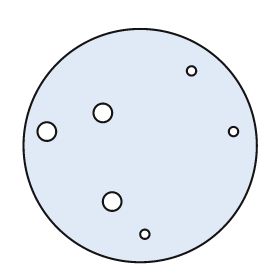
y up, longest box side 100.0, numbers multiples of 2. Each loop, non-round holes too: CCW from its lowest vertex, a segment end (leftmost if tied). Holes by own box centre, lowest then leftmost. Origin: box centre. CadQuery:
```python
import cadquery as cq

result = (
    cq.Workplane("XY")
    .moveTo(0.0, 0.0)
    .circle(50.0)
    .moveTo(2.0, -38.0)
    .circle(2.0)
    .moveTo(-12.0, -24.0)
    .circle(4.0)
    .moveTo(-40.0, 6.0)
    .circle(4.0)
    .moveTo(40.0, 6.0)
    .circle(2.0)
    .moveTo(-16.0, 14.0)
    .circle(4.0)
    .moveTo(22.0, 32.0)
    .circle(2.0)
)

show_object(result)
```